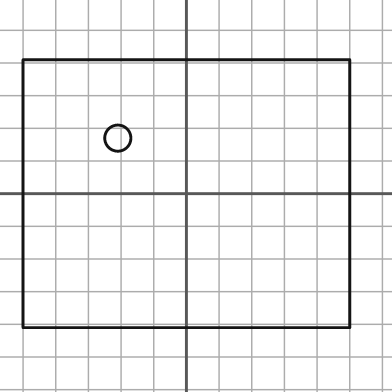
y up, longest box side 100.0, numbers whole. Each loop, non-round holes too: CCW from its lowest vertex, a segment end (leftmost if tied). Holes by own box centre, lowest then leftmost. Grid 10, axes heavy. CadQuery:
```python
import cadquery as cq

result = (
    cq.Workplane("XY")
    .moveTo(-50.0, -41.0)
    .lineTo(50.0, -41.0)
    .lineTo(50.0, 41.0)
    .lineTo(-50.0, 41.0)
    .close()
    .moveTo(-21.0, 17.0)
    .circle(4.0)
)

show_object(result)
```